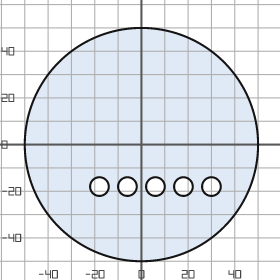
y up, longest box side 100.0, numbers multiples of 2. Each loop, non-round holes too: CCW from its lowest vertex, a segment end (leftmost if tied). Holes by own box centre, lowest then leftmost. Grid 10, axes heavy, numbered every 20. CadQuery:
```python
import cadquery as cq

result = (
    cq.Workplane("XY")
    .moveTo(0.0, 0.0)
    .circle(50.0)
    .moveTo(-18.0, -18.0)
    .circle(4.0)
    .moveTo(-6.0, -18.0)
    .circle(4.0)
    .moveTo(6.0, -18.0)
    .circle(4.0)
    .moveTo(18.0, -18.0)
    .circle(4.0)
    .moveTo(30.0, -18.0)
    .circle(4.0)
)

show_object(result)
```